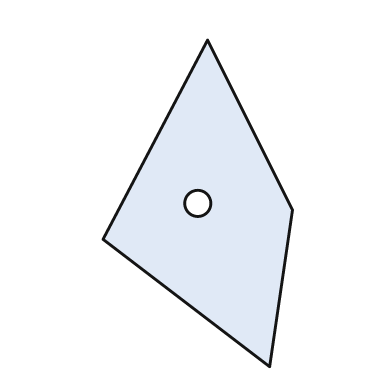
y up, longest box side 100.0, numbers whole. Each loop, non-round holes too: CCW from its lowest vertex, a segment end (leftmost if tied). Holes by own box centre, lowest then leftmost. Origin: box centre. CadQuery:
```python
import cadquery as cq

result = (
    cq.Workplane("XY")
    .moveTo(22.0, -50.0)
    .lineTo(29.0, -2.0)
    .lineTo(3.0, 50.0)
    .lineTo(-29.0, -11.0)
    .close()
    .moveTo(0.0, 0.0)
    .circle(4.0)
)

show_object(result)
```